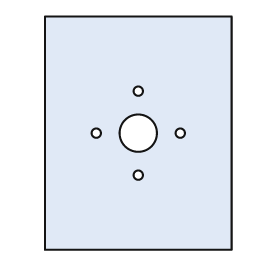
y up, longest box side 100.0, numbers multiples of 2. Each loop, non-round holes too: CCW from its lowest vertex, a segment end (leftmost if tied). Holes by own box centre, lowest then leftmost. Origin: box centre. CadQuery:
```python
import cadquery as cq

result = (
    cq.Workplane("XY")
    .moveTo(-40.0, -50.0)
    .lineTo(40.0, -50.0)
    .lineTo(40.0, 50.0)
    .lineTo(-40.0, 50.0)
    .close()
    .moveTo(0.0, -18.0)
    .circle(2.0)
    .moveTo(-18.0, 0.0)
    .circle(2.0)
    .moveTo(0.0, 0.0)
    .circle(8.0)
    .moveTo(18.0, 0.0)
    .circle(2.0)
    .moveTo(0.0, 18.0)
    .circle(2.0)
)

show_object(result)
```